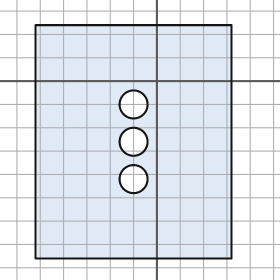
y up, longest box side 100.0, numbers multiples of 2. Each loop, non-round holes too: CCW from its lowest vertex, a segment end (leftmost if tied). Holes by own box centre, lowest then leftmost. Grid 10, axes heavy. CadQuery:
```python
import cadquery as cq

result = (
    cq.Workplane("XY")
    .moveTo(-52.0, -76.0)
    .lineTo(32.0, -76.0)
    .lineTo(32.0, 24.0)
    .lineTo(-52.0, 24.0)
    .close()
    .moveTo(-10.0, -42.0)
    .circle(6.0)
    .moveTo(-10.0, -26.0)
    .circle(6.0)
    .moveTo(-10.0, -10.0)
    .circle(6.0)
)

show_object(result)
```